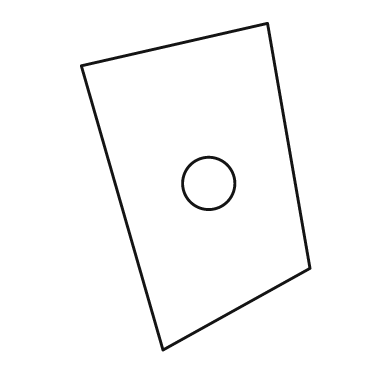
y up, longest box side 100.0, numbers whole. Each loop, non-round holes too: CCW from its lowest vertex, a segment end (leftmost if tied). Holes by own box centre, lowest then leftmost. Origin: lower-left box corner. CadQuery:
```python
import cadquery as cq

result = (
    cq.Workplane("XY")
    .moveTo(25.0, 0.0)
    .lineTo(70.0, 25.0)
    .lineTo(57.0, 100.0)
    .lineTo(0.0, 87.0)
    .close()
    .moveTo(39.0, 51.0)
    .circle(8.0)
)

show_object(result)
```